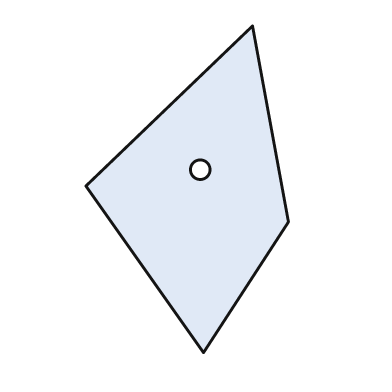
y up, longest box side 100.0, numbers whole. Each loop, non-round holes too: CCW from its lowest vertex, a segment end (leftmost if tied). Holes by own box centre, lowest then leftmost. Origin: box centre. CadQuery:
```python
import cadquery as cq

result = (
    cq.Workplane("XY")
    .moveTo(5.0, -50.0)
    .lineTo(31.0, -10.0)
    .lineTo(20.0, 50.0)
    .lineTo(-31.0, 1.0)
    .close()
    .moveTo(4.0, 6.0)
    .circle(3.0)
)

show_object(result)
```